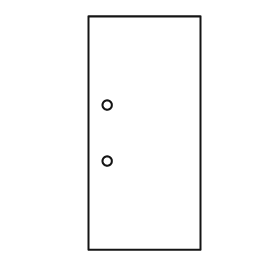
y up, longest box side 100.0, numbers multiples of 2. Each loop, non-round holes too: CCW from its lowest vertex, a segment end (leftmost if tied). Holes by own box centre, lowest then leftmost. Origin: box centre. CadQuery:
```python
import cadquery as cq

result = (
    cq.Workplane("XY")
    .moveTo(-24.0, -50.0)
    .lineTo(24.0, -50.0)
    .lineTo(24.0, 50.0)
    .lineTo(-24.0, 50.0)
    .close()
    .moveTo(-16.0, -12.0)
    .circle(2.0)
    .moveTo(-16.0, 12.0)
    .circle(2.0)
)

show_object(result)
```